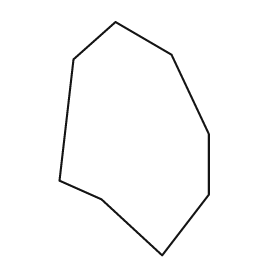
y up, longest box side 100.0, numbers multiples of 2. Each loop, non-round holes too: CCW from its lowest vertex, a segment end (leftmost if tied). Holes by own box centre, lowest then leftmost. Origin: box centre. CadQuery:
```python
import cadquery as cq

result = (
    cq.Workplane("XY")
    .moveTo(12.0, -50.0)
    .lineTo(32.0, -24.0)
    .lineTo(32.0, 2.0)
    .lineTo(16.0, 36.0)
    .lineTo(-8.0, 50.0)
    .lineTo(-26.0, 34.0)
    .lineTo(-32.0, -18.0)
    .lineTo(-14.0, -26.0)
    .close()
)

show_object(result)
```